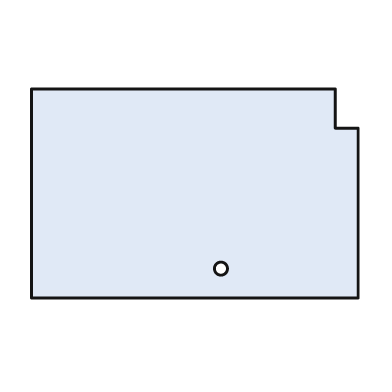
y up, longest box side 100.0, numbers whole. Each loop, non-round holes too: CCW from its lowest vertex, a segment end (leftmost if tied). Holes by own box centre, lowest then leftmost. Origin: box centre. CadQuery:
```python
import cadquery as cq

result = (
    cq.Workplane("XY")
    .moveTo(-50.0, -32.0)
    .lineTo(50.0, -32.0)
    .lineTo(50.0, 20.0)
    .lineTo(43.0, 20.0)
    .lineTo(43.0, 32.0)
    .lineTo(-50.0, 32.0)
    .close()
    .moveTo(8.0, -23.0)
    .circle(2.0)
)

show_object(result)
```